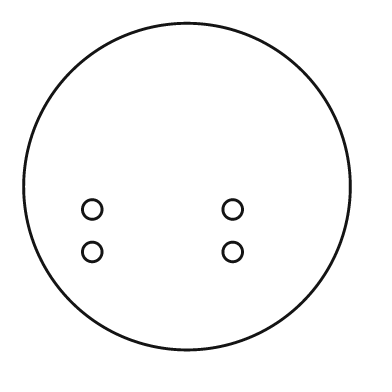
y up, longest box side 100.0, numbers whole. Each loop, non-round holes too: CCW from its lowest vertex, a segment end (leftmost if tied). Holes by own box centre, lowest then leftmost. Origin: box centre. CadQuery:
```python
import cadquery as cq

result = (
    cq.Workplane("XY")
    .moveTo(0.0, 0.0)
    .circle(50.0)
    .moveTo(-29.0, -20.0)
    .circle(3.0)
    .moveTo(14.0, -20.0)
    .circle(3.0)
    .moveTo(-29.0, -7.0)
    .circle(3.0)
    .moveTo(14.0, -7.0)
    .circle(3.0)
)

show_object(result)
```